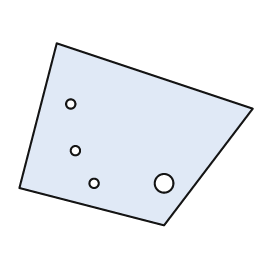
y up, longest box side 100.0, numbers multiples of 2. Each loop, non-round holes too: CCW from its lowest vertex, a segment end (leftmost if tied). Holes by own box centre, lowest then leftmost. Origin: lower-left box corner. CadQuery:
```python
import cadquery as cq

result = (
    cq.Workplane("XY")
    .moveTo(62.0, 0.0)
    .lineTo(100.0, 50.0)
    .lineTo(16.0, 78.0)
    .lineTo(0.0, 16.0)
    .close()
    .moveTo(32.0, 18.0)
    .circle(2.0)
    .moveTo(62.0, 18.0)
    .circle(4.0)
    .moveTo(24.0, 32.0)
    .circle(2.0)
    .moveTo(22.0, 52.0)
    .circle(2.0)
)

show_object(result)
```